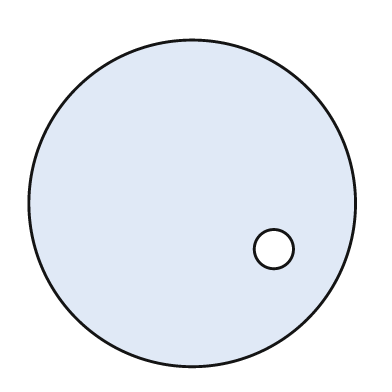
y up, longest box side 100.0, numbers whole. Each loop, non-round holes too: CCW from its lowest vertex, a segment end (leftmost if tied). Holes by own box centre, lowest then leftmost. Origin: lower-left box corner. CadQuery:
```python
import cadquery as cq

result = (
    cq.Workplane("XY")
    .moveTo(50.0, 50.0)
    .circle(50.0)
    .moveTo(75.0, 36.0)
    .circle(6.0)
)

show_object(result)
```